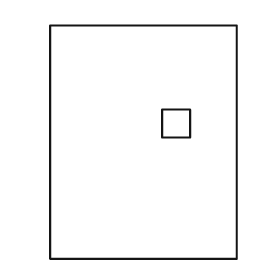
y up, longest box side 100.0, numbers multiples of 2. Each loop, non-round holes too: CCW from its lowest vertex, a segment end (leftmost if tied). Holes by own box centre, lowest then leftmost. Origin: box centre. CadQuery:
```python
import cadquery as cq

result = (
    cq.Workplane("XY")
    .moveTo(-40.0, -50.0)
    .lineTo(40.0, -50.0)
    .lineTo(40.0, 50.0)
    .lineTo(-40.0, 50.0)
    .close()
    .moveTo(8.0, 2.0)
    .lineTo(20.0, 2.0)
    .lineTo(20.0, 14.0)
    .lineTo(8.0, 14.0)
    .close()
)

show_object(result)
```